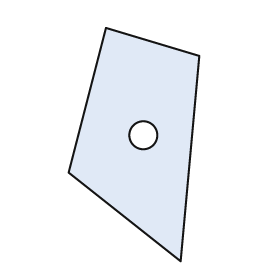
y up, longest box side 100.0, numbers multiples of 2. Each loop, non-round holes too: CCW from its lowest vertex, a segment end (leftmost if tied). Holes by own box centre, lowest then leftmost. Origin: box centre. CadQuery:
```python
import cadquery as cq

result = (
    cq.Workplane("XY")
    .moveTo(20.0, -50.0)
    .lineTo(28.0, 38.0)
    .lineTo(-12.0, 50.0)
    .lineTo(-28.0, -12.0)
    .close()
    .moveTo(4.0, 4.0)
    .circle(6.0)
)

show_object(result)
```